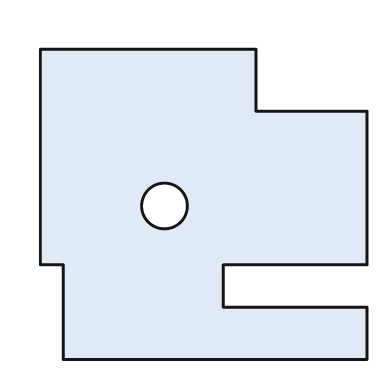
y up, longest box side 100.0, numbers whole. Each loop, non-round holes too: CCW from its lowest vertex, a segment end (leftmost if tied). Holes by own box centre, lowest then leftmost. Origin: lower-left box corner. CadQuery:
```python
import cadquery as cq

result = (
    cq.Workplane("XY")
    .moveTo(7.0, 0.0)
    .lineTo(100.0, 0.0)
    .lineTo(100.0, 16.0)
    .lineTo(56.0, 16.0)
    .lineTo(56.0, 29.0)
    .lineTo(100.0, 29.0)
    .lineTo(100.0, 76.0)
    .lineTo(66.0, 76.0)
    .lineTo(66.0, 95.0)
    .lineTo(0.0, 95.0)
    .lineTo(0.0, 29.0)
    .lineTo(7.0, 29.0)
    .close()
    .moveTo(38.0, 47.0)
    .circle(7.0)
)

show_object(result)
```